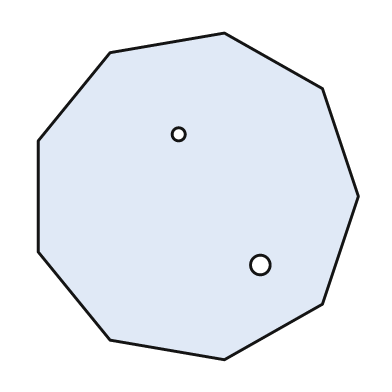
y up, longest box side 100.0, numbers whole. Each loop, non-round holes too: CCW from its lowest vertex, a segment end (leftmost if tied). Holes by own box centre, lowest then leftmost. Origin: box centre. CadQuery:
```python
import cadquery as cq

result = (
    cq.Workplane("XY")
    .moveTo(8.0, -50.0)
    .lineTo(38.0, -33.0)
    .lineTo(49.0, 0.0)
    .lineTo(38.0, 33.0)
    .lineTo(8.0, 50.0)
    .lineTo(-27.0, 44.0)
    .lineTo(-49.0, 17.0)
    .lineTo(-49.0, -17.0)
    .lineTo(-27.0, -44.0)
    .close()
    .moveTo(19.0, -21.0)
    .circle(3.0)
    .moveTo(-6.0, 19.0)
    .circle(2.0)
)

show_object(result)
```